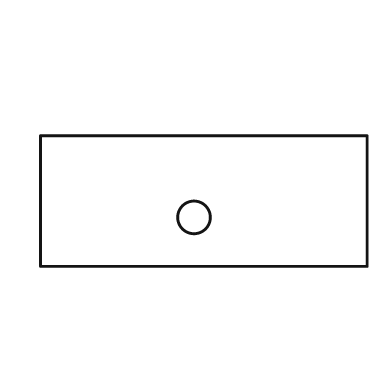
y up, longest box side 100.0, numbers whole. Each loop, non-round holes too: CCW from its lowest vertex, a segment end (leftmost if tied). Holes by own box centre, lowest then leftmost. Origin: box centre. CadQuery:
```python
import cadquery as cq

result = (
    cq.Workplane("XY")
    .moveTo(-50.0, -20.0)
    .lineTo(50.0, -20.0)
    .lineTo(50.0, 20.0)
    .lineTo(-50.0, 20.0)
    .close()
    .moveTo(-3.0, -5.0)
    .circle(5.0)
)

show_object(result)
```